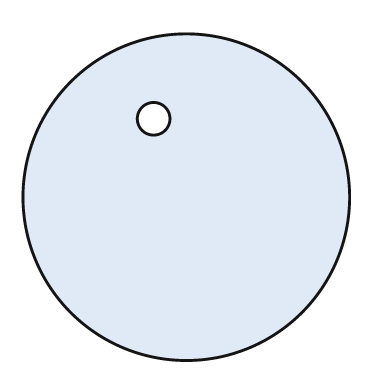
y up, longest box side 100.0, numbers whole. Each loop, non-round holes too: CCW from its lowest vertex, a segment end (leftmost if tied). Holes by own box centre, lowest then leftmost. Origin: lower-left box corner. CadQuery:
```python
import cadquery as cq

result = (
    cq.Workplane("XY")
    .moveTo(50.0, 50.0)
    .circle(50.0)
    .moveTo(40.0, 74.0)
    .circle(5.0)
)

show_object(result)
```